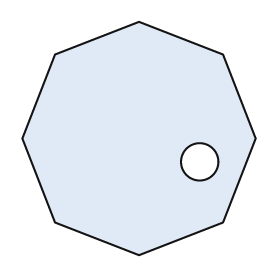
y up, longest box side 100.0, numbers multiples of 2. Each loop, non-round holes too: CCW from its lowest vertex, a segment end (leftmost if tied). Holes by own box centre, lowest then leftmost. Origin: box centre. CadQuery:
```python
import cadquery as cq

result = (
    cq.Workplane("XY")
    .moveTo(0.0, -50.0)
    .lineTo(36.0, -36.0)
    .lineTo(50.0, 0.0)
    .lineTo(36.0, 36.0)
    .lineTo(0.0, 50.0)
    .lineTo(-36.0, 36.0)
    .lineTo(-50.0, 0.0)
    .lineTo(-36.0, -36.0)
    .close()
    .moveTo(26.0, -10.0)
    .circle(8.0)
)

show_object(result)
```